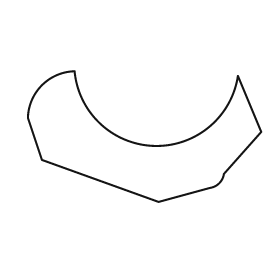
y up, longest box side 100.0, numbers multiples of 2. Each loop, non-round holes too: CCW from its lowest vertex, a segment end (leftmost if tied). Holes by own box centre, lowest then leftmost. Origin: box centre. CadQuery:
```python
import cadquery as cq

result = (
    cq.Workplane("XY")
    .moveTo(6.0, -28.0)
    .lineTo(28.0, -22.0)
    .threePointArc((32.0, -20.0), (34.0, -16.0))
    .lineTo(50.0, 2.0)
    .lineTo(40.0, 26.0)
    .threePointArc((4.0, -4.0), (-30.0, 28.0))
    .threePointArc((-44.0, 22.0), (-50.0, 8.0))
    .lineTo(-44.0, -10.0)
    .close()
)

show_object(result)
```